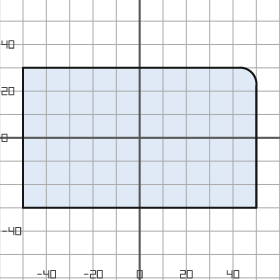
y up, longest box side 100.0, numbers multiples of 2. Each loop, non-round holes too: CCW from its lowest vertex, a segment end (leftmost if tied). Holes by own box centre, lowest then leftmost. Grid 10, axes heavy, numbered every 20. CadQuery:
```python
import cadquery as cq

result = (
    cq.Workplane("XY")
    .moveTo(-50.0, -30.0)
    .lineTo(50.0, -30.0)
    .lineTo(50.0, 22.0)
    .threePointArc((48.0, 28.0), (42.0, 30.0))
    .lineTo(-50.0, 30.0)
    .close()
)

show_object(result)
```